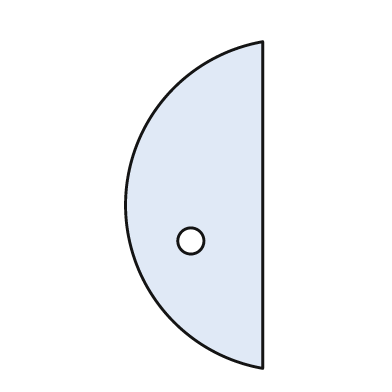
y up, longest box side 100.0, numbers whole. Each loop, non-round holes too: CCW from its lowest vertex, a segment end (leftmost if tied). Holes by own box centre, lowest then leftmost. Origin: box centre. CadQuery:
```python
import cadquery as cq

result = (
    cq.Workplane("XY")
    .moveTo(21.0, -50.0)
    .lineTo(21.0, 50.0)
    .threePointArc((-21.0, 0.0), (21.0, -50.0))
    .close()
    .moveTo(-1.0, -11.0)
    .circle(4.0)
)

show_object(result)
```